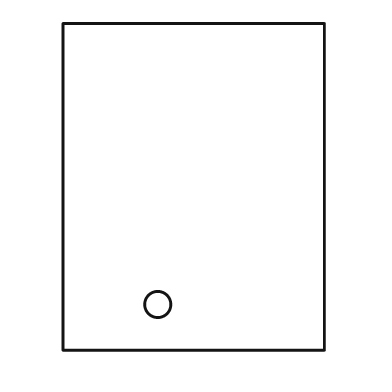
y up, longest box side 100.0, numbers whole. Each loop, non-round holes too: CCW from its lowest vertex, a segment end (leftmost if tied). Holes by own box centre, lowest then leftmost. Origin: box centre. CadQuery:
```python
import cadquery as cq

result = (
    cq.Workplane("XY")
    .moveTo(-40.0, -50.0)
    .lineTo(40.0, -50.0)
    .lineTo(40.0, 50.0)
    .lineTo(-40.0, 50.0)
    .close()
    .moveTo(-11.0, -36.0)
    .circle(4.0)
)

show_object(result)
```